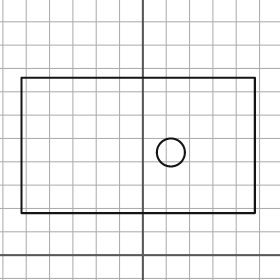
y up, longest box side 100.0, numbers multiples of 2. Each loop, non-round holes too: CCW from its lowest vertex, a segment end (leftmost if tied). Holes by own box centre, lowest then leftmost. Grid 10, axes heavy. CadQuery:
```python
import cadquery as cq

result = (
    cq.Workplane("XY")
    .moveTo(-52.0, 18.0)
    .lineTo(48.0, 18.0)
    .lineTo(48.0, 76.0)
    .lineTo(-52.0, 76.0)
    .close()
    .moveTo(12.0, 44.0)
    .circle(6.0)
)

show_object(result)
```